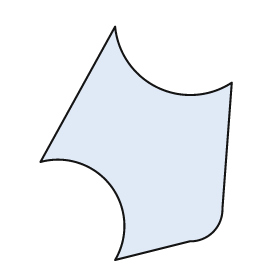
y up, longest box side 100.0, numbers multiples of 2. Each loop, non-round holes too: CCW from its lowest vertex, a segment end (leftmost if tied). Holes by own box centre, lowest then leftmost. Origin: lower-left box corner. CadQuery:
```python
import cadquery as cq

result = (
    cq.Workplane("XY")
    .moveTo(32.0, 0.0)
    .lineTo(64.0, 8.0)
    .threePointArc((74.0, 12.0), (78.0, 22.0))
    .lineTo(82.0, 76.0)
    .threePointArc((50.0, 74.0), (32.0, 100.0))
    .lineTo(0.0, 42.0)
    .threePointArc((30.0, 32.0), (32.0, 0.0))
    .close()
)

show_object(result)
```